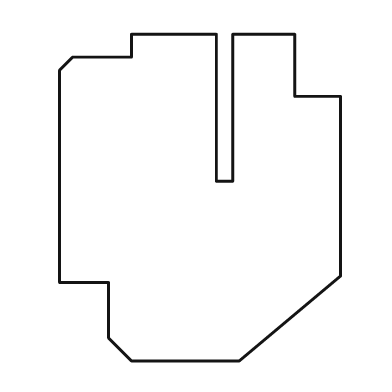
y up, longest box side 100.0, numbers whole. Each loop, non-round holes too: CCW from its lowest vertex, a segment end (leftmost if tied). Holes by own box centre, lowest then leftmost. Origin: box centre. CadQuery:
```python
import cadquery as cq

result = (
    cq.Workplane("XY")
    .moveTo(-21.0, -50.0)
    .lineTo(12.0, -50.0)
    .lineTo(43.0, -24.0)
    .lineTo(43.0, 31.0)
    .lineTo(29.0, 31.0)
    .lineTo(29.0, 50.0)
    .lineTo(10.0, 50.0)
    .lineTo(10.0, 5.0)
    .lineTo(5.0, 5.0)
    .lineTo(5.0, 50.0)
    .lineTo(-21.0, 50.0)
    .lineTo(-21.0, 43.0)
    .lineTo(-39.0, 43.0)
    .lineTo(-43.0, 39.0)
    .lineTo(-43.0, -26.0)
    .lineTo(-28.0, -26.0)
    .lineTo(-28.0, -43.0)
    .close()
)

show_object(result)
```